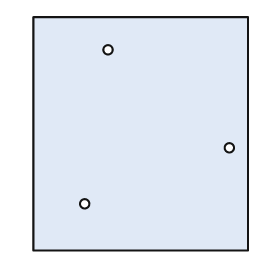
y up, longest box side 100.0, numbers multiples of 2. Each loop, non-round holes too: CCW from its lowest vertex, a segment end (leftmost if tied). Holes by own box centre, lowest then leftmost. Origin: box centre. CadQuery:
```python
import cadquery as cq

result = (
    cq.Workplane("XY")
    .moveTo(-46.0, -50.0)
    .lineTo(46.0, -50.0)
    .lineTo(46.0, 50.0)
    .lineTo(-46.0, 50.0)
    .close()
    .moveTo(-24.0, -30.0)
    .circle(2.0)
    .moveTo(38.0, -6.0)
    .circle(2.0)
    .moveTo(-14.0, 36.0)
    .circle(2.0)
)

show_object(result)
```